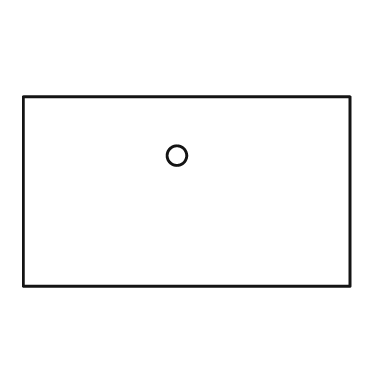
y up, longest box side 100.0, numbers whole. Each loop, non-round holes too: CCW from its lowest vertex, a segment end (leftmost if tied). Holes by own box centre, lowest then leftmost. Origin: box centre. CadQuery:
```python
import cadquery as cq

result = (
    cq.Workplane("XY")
    .moveTo(-50.0, -29.0)
    .lineTo(50.0, -29.0)
    .lineTo(50.0, 29.0)
    .lineTo(-50.0, 29.0)
    .close()
    .moveTo(-3.0, 11.0)
    .circle(3.0)
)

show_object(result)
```